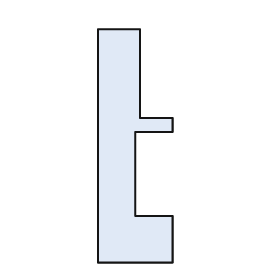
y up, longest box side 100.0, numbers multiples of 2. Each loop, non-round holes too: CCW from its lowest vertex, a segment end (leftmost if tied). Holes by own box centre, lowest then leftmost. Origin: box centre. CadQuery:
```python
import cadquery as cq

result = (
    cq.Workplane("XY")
    .moveTo(-16.0, -50.0)
    .lineTo(16.0, -50.0)
    .lineTo(16.0, -30.0)
    .lineTo(0.0, -30.0)
    .lineTo(0.0, 6.0)
    .lineTo(16.0, 6.0)
    .lineTo(16.0, 12.0)
    .lineTo(2.0, 12.0)
    .lineTo(2.0, 50.0)
    .lineTo(-16.0, 50.0)
    .close()
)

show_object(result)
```